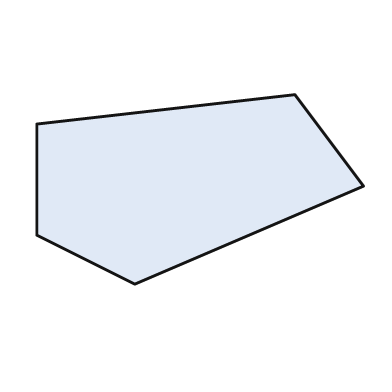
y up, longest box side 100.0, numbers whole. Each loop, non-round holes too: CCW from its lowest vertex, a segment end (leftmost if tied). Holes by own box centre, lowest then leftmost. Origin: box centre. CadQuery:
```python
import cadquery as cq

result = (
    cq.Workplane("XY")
    .moveTo(-20.0, -29.0)
    .lineTo(50.0, 1.0)
    .lineTo(29.0, 29.0)
    .lineTo(-50.0, 20.0)
    .lineTo(-50.0, -14.0)
    .close()
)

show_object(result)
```